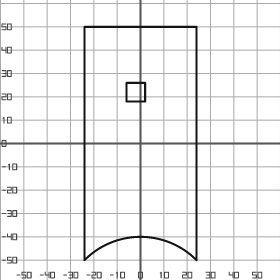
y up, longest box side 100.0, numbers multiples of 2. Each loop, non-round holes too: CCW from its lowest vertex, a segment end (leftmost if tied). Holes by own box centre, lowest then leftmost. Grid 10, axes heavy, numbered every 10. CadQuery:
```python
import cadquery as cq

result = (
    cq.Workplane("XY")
    .moveTo(-24.0, -50.0)
    .threePointArc((0.0, -40.0), (24.0, -50.0))
    .lineTo(24.0, 50.0)
    .lineTo(-24.0, 50.0)
    .close()
    .moveTo(-6.0, 18.0)
    .lineTo(2.0, 18.0)
    .lineTo(2.0, 26.0)
    .lineTo(-6.0, 26.0)
    .close()
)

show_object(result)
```